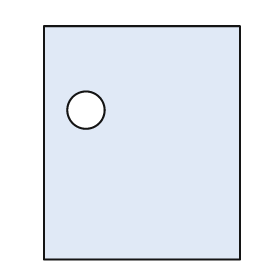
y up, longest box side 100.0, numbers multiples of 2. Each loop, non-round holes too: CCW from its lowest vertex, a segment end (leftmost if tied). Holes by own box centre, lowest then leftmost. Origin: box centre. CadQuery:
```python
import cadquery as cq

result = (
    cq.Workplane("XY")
    .moveTo(-42.0, -50.0)
    .lineTo(42.0, -50.0)
    .lineTo(42.0, 50.0)
    .lineTo(-42.0, 50.0)
    .close()
    .moveTo(-24.0, 14.0)
    .circle(8.0)
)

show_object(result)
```